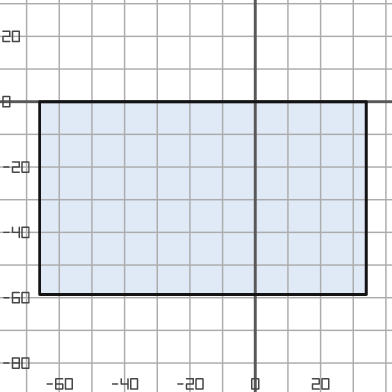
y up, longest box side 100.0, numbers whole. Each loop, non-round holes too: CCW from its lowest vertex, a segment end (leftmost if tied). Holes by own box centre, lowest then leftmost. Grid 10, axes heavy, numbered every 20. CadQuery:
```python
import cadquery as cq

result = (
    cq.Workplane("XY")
    .moveTo(-66.0, -59.0)
    .lineTo(34.0, -59.0)
    .lineTo(34.0, 0.0)
    .lineTo(-66.0, 0.0)
    .close()
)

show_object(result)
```